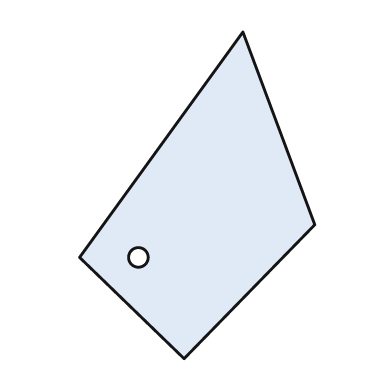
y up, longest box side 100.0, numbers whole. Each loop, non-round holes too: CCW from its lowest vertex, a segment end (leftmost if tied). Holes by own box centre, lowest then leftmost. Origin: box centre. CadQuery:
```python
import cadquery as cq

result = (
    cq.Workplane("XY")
    .moveTo(-4.0, -50.0)
    .lineTo(36.0, -9.0)
    .lineTo(14.0, 50.0)
    .lineTo(-36.0, -19.0)
    .close()
    .moveTo(-18.0, -19.0)
    .circle(3.0)
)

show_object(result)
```